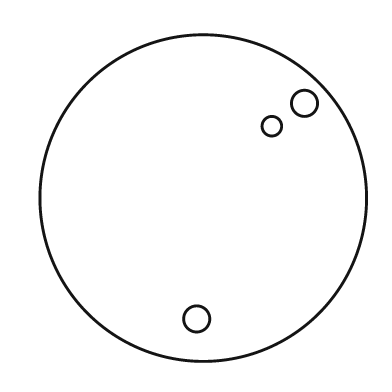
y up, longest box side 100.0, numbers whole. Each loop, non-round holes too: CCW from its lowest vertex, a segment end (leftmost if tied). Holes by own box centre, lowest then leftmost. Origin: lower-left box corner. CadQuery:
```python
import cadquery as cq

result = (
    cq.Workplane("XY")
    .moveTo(50.0, 50.0)
    .circle(50.0)
    .moveTo(48.0, 13.0)
    .circle(4.0)
    .moveTo(71.0, 72.0)
    .circle(3.0)
    .moveTo(81.0, 79.0)
    .circle(4.0)
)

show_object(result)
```